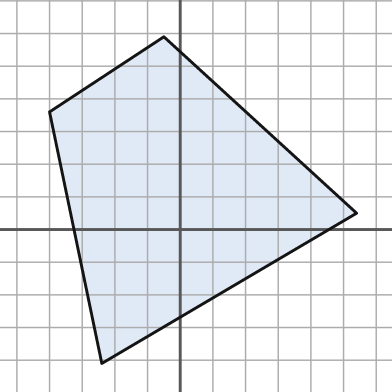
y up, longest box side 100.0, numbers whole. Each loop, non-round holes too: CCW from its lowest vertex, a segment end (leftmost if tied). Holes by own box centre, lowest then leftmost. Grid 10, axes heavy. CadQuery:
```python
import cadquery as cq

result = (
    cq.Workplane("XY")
    .moveTo(-24.0, -41.0)
    .lineTo(54.0, 5.0)
    .lineTo(-5.0, 59.0)
    .lineTo(-40.0, 36.0)
    .close()
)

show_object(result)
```